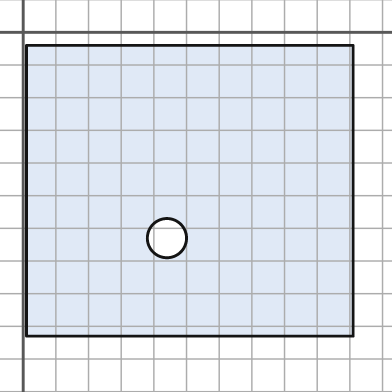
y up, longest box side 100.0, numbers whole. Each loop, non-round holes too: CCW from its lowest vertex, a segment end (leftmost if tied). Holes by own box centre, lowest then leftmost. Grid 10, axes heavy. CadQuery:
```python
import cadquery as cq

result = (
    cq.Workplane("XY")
    .moveTo(1.0, -93.0)
    .lineTo(101.0, -93.0)
    .lineTo(101.0, -4.0)
    .lineTo(1.0, -4.0)
    .close()
    .moveTo(44.0, -63.0)
    .circle(6.0)
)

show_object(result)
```